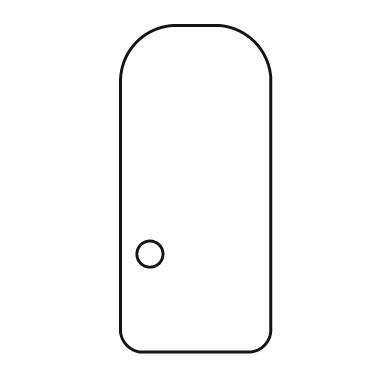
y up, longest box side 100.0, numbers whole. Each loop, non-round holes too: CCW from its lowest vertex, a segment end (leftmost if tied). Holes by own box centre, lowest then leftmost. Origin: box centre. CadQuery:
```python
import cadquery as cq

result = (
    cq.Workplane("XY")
    .moveTo(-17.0, -50.0)
    .lineTo(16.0, -50.0)
    .threePointArc((21.0, -48.0), (23.0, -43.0))
    .lineTo(23.0, 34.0)
    .threePointArc((18.0, 45.0), (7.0, 50.0))
    .lineTo(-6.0, 50.0)
    .threePointArc((-18.0, 45.0), (-23.0, 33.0))
    .lineTo(-23.0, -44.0)
    .threePointArc((-21.0, -48.0), (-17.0, -50.0))
    .close()
    .moveTo(-14.0, -20.0)
    .circle(4.0)
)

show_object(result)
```